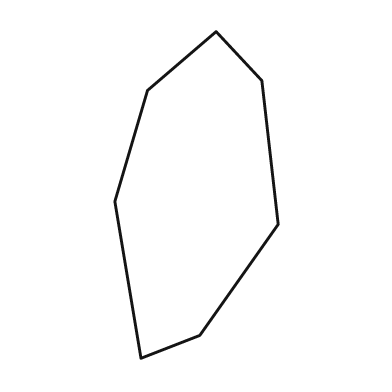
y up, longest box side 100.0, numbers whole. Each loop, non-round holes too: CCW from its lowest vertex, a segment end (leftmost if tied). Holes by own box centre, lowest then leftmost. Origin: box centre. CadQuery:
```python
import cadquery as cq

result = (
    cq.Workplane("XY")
    .moveTo(-17.0, -50.0)
    .lineTo(1.0, -43.0)
    .lineTo(25.0, -9.0)
    .lineTo(20.0, 35.0)
    .lineTo(6.0, 50.0)
    .lineTo(-15.0, 32.0)
    .lineTo(-25.0, -2.0)
    .close()
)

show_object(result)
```